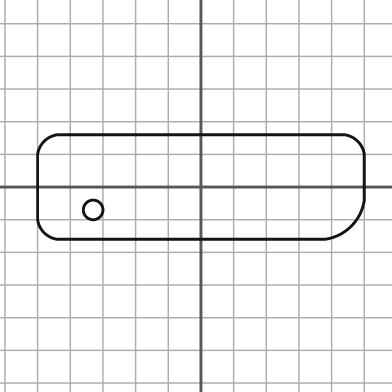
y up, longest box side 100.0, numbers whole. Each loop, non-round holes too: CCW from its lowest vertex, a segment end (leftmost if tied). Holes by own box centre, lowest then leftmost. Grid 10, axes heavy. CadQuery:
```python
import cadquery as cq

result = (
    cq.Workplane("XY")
    .moveTo(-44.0, -16.0)
    .lineTo(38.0, -16.0)
    .threePointArc((46.0, -12.0), (50.0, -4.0))
    .lineTo(50.0, 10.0)
    .threePointArc((48.0, 14.0), (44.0, 16.0))
    .lineTo(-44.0, 16.0)
    .threePointArc((-48.0, 14.0), (-50.0, 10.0))
    .lineTo(-50.0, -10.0)
    .threePointArc((-48.0, -14.0), (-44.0, -16.0))
    .close()
    .moveTo(-33.0, -7.0)
    .circle(3.0)
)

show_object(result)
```